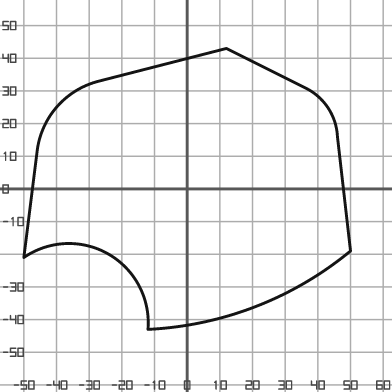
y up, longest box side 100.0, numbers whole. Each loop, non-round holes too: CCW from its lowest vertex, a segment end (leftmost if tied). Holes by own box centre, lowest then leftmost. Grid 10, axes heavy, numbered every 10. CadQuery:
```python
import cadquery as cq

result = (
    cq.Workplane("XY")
    .moveTo(-12.0, -43.0)
    .threePointArc((21.0, -36.0), (50.0, -19.0))
    .lineTo(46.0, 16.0)
    .threePointArc((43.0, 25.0), (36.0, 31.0))
    .lineTo(12.0, 43.0)
    .lineTo(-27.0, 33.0)
    .threePointArc((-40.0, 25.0), (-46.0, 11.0))
    .lineTo(-50.0, -21.0)
    .threePointArc((-24.0, -20.0), (-12.0, -43.0))
    .close()
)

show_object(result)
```